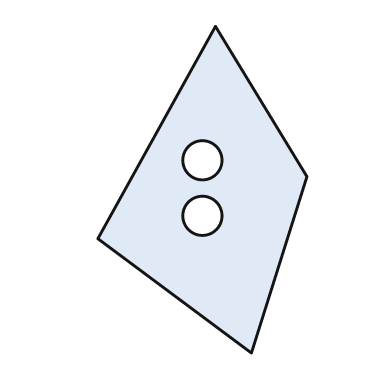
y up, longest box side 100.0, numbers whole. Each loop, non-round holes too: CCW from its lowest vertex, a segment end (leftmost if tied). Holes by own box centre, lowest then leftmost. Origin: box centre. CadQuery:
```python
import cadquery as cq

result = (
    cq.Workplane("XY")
    .moveTo(15.0, -50.0)
    .lineTo(32.0, 4.0)
    .lineTo(4.0, 50.0)
    .lineTo(-32.0, -15.0)
    .close()
    .moveTo(0.0, -8.0)
    .circle(6.0)
    .moveTo(0.0, 9.0)
    .circle(6.0)
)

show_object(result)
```